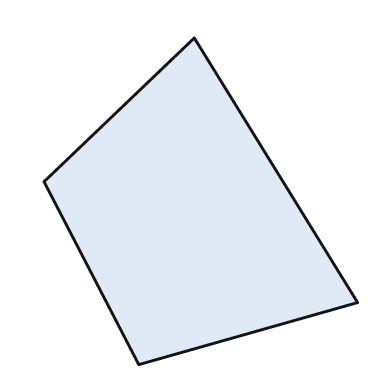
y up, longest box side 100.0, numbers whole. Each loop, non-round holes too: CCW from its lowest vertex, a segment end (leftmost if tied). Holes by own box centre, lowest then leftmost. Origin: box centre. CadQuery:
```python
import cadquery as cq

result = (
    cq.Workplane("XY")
    .moveTo(-19.0, -50.0)
    .lineTo(48.0, -31.0)
    .lineTo(-2.0, 50.0)
    .lineTo(-48.0, 6.0)
    .close()
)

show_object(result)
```